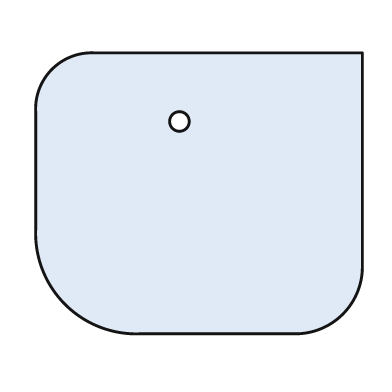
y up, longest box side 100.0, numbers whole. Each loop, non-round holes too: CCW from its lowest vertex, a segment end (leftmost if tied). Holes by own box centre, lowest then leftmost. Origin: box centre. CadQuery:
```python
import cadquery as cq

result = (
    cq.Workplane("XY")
    .moveTo(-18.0, -43.0)
    .lineTo(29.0, -43.0)
    .threePointArc((44.0, -37.0), (50.0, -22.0))
    .lineTo(50.0, 43.0)
    .lineTo(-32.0, 43.0)
    .threePointArc((-45.0, 38.0), (-50.0, 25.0))
    .lineTo(-50.0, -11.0)
    .threePointArc((-41.0, -34.0), (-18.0, -43.0))
    .close()
    .moveTo(-6.0, 22.0)
    .circle(3.0)
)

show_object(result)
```